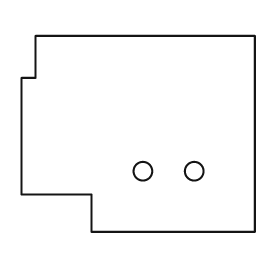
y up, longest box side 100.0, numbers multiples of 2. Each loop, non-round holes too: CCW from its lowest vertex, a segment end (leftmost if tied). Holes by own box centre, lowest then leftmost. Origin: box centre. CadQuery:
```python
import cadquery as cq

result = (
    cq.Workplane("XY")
    .moveTo(-20.0, -42.0)
    .lineTo(50.0, -42.0)
    .lineTo(50.0, 42.0)
    .lineTo(-44.0, 42.0)
    .lineTo(-44.0, 24.0)
    .lineTo(-50.0, 24.0)
    .lineTo(-50.0, -26.0)
    .lineTo(-20.0, -26.0)
    .close()
    .moveTo(2.0, -16.0)
    .circle(4.0)
    .moveTo(24.0, -16.0)
    .circle(4.0)
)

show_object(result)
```